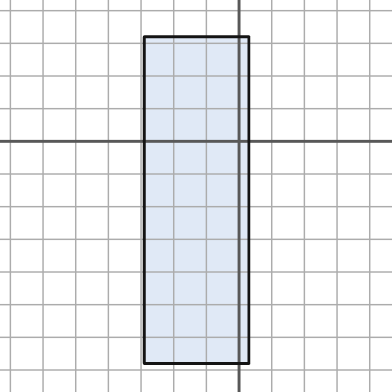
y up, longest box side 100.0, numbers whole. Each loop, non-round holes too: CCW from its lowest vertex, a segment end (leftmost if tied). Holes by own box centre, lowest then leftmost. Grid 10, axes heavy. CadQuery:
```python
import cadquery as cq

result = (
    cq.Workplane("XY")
    .moveTo(-29.0, -68.0)
    .lineTo(3.0, -68.0)
    .lineTo(3.0, 32.0)
    .lineTo(-29.0, 32.0)
    .close()
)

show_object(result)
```